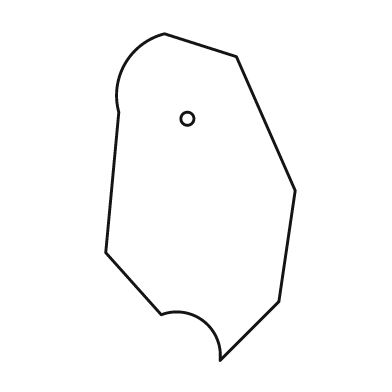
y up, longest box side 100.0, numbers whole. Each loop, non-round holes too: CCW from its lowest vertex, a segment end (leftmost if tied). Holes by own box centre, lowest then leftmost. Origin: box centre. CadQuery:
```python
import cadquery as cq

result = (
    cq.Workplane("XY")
    .moveTo(6.0, -50.0)
    .lineTo(24.0, -32.0)
    .lineTo(29.0, 2.0)
    .lineTo(11.0, 43.0)
    .lineTo(-11.0, 50.0)
    .threePointArc((-23.0, 41.0), (-25.0, 26.0))
    .lineTo(-29.0, -17.0)
    .lineTo(-12.0, -36.0)
    .threePointArc((1.0, -38.0), (6.0, -50.0))
    .close()
    .moveTo(-4.0, 24.0)
    .circle(2.0)
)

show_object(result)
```